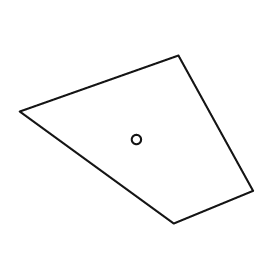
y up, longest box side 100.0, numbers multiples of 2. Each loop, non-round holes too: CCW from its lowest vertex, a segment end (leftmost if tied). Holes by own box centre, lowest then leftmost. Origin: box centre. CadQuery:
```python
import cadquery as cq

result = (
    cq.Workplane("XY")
    .moveTo(16.0, -36.0)
    .lineTo(50.0, -22.0)
    .lineTo(18.0, 36.0)
    .lineTo(-50.0, 12.0)
    .close()
    .moveTo(0.0, 0.0)
    .circle(2.0)
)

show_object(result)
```